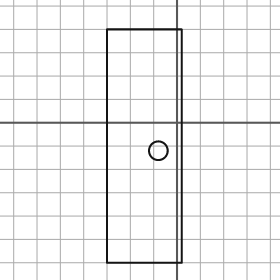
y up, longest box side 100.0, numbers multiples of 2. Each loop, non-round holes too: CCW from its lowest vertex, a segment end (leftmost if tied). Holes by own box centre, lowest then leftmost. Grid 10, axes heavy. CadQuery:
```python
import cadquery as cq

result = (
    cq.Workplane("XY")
    .moveTo(-30.0, -60.0)
    .lineTo(2.0, -60.0)
    .lineTo(2.0, 40.0)
    .lineTo(-30.0, 40.0)
    .close()
    .moveTo(-8.0, -12.0)
    .circle(4.0)
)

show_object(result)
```